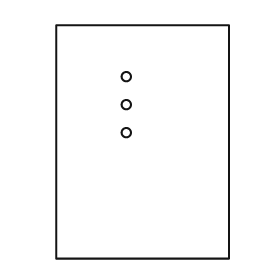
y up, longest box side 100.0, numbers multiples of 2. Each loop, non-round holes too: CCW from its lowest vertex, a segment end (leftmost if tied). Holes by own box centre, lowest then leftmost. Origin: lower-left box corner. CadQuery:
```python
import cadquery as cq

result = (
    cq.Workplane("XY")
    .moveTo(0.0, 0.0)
    .lineTo(74.0, 0.0)
    .lineTo(74.0, 100.0)
    .lineTo(0.0, 100.0)
    .close()
    .moveTo(30.0, 54.0)
    .circle(2.0)
    .moveTo(30.0, 66.0)
    .circle(2.0)
    .moveTo(30.0, 78.0)
    .circle(2.0)
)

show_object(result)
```